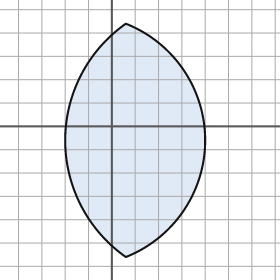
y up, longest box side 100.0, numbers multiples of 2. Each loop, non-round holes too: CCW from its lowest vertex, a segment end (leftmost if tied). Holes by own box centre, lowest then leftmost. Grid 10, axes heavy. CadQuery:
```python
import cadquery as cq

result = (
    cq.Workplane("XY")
    .moveTo(6.0, -56.0)
    .threePointArc((40.0, -6.0), (6.0, 44.0))
    .threePointArc((-20.0, -6.0), (6.0, -56.0))
    .close()
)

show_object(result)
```